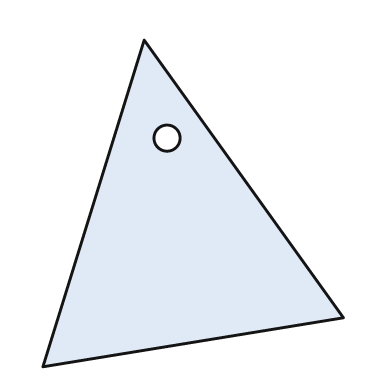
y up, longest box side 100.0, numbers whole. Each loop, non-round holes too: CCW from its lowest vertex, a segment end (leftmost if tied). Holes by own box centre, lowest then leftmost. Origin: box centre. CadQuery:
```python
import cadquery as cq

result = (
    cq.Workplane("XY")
    .moveTo(-46.0, -50.0)
    .lineTo(46.0, -35.0)
    .lineTo(-15.0, 50.0)
    .close()
    .moveTo(-8.0, 20.0)
    .circle(4.0)
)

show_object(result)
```